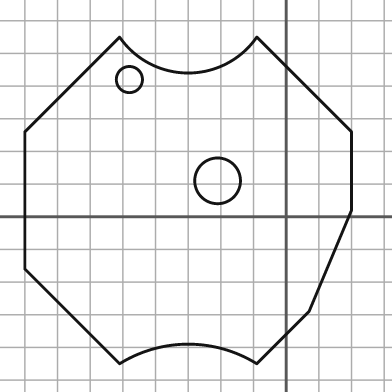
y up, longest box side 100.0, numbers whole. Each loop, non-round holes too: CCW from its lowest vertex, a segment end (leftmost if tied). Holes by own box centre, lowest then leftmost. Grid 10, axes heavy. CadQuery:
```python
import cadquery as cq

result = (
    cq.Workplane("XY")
    .moveTo(-51.0, -45.0)
    .threePointArc((-30.0, -39.0), (-9.0, -45.0))
    .lineTo(7.0, -29.0)
    .lineTo(20.0, 2.0)
    .lineTo(20.0, 26.0)
    .lineTo(-9.0, 55.0)
    .threePointArc((-30.0, 44.0), (-51.0, 55.0))
    .lineTo(-80.0, 26.0)
    .lineTo(-80.0, -16.0)
    .close()
    .moveTo(-21.0, 11.0)
    .circle(7.0)
    .moveTo(-48.0, 42.0)
    .circle(4.0)
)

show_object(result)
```